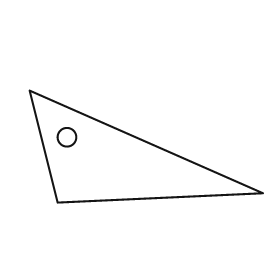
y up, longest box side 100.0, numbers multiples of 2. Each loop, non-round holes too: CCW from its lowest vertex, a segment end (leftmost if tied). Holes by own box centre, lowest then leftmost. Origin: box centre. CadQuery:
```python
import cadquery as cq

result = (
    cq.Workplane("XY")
    .moveTo(-38.0, -24.0)
    .lineTo(50.0, -20.0)
    .lineTo(-50.0, 24.0)
    .close()
    .moveTo(-34.0, 4.0)
    .circle(4.0)
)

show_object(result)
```